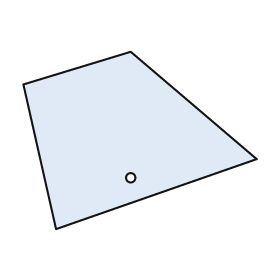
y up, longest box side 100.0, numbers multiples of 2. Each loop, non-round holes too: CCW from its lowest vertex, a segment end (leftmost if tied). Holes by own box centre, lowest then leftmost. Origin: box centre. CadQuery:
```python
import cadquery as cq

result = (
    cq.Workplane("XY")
    .moveTo(-36.0, -38.0)
    .lineTo(50.0, -8.0)
    .lineTo(-4.0, 38.0)
    .lineTo(-50.0, 24.0)
    .close()
    .moveTo(-4.0, -16.0)
    .circle(2.0)
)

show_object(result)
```